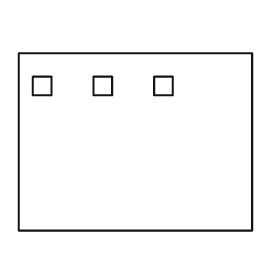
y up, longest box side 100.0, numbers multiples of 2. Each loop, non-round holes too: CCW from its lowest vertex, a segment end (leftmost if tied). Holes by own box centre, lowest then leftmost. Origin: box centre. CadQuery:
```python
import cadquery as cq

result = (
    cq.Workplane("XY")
    .moveTo(-50.0, -38.0)
    .lineTo(50.0, -38.0)
    .lineTo(50.0, 38.0)
    .lineTo(-50.0, 38.0)
    .close()
    .moveTo(-44.0, 20.0)
    .lineTo(-36.0, 20.0)
    .lineTo(-36.0, 28.0)
    .lineTo(-44.0, 28.0)
    .close()
    .moveTo(-18.0, 20.0)
    .lineTo(-10.0, 20.0)
    .lineTo(-10.0, 28.0)
    .lineTo(-18.0, 28.0)
    .close()
    .moveTo(8.0, 20.0)
    .lineTo(16.0, 20.0)
    .lineTo(16.0, 28.0)
    .lineTo(8.0, 28.0)
    .close()
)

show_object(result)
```